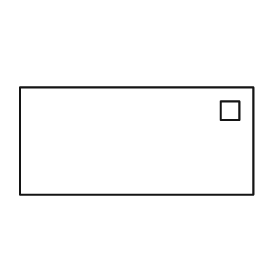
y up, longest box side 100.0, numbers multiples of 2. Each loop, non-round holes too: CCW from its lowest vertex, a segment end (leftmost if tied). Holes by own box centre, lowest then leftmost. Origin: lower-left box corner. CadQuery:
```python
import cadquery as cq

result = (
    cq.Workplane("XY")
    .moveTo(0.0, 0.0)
    .lineTo(100.0, 0.0)
    .lineTo(100.0, 46.0)
    .lineTo(0.0, 46.0)
    .close()
    .moveTo(86.0, 32.0)
    .lineTo(94.0, 32.0)
    .lineTo(94.0, 40.0)
    .lineTo(86.0, 40.0)
    .close()
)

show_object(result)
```